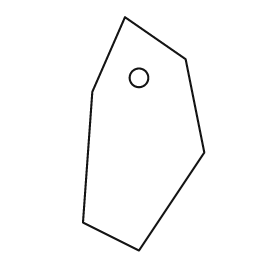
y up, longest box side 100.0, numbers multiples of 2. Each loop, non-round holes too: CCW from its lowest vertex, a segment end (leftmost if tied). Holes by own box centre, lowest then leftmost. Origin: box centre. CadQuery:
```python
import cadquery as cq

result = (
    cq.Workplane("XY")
    .moveTo(-2.0, -50.0)
    .lineTo(26.0, -8.0)
    .lineTo(18.0, 32.0)
    .lineTo(-8.0, 50.0)
    .lineTo(-22.0, 18.0)
    .lineTo(-26.0, -38.0)
    .close()
    .moveTo(-2.0, 24.0)
    .circle(4.0)
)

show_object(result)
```